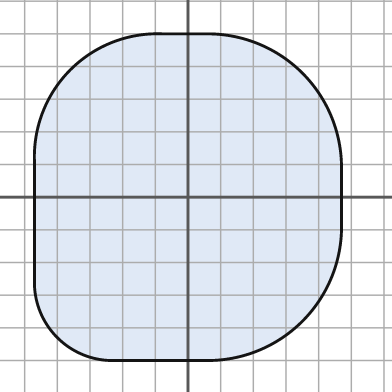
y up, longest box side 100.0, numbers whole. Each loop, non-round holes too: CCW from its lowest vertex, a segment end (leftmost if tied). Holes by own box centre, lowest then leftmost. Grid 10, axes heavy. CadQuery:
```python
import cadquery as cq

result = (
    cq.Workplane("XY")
    .moveTo(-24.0, -50.0)
    .lineTo(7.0, -50.0)
    .threePointArc((35.0, -38.0), (47.0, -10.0))
    .lineTo(47.0, 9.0)
    .threePointArc((35.0, 38.0), (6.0, 50.0))
    .lineTo(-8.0, 50.0)
    .threePointArc((-36.0, 39.0), (-47.0, 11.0))
    .lineTo(-47.0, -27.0)
    .threePointArc((-40.0, -43.0), (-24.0, -50.0))
    .close()
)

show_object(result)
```